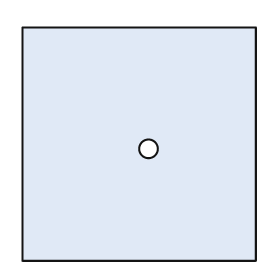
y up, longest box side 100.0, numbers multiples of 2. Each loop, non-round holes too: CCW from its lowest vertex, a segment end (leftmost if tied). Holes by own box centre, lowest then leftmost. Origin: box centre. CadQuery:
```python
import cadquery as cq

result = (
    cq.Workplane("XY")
    .moveTo(-50.0, -50.0)
    .lineTo(50.0, -50.0)
    .lineTo(50.0, 50.0)
    .lineTo(-50.0, 50.0)
    .close()
    .moveTo(4.0, -2.0)
    .circle(4.0)
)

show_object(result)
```